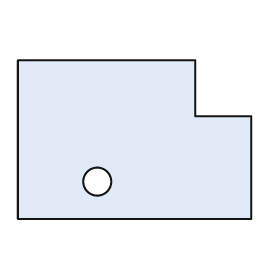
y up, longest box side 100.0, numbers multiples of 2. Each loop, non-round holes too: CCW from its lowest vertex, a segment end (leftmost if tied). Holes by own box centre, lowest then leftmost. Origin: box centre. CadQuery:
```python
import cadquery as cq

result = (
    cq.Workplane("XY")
    .moveTo(-50.0, -34.0)
    .lineTo(50.0, -34.0)
    .lineTo(50.0, 10.0)
    .lineTo(26.0, 10.0)
    .lineTo(26.0, 34.0)
    .lineTo(-50.0, 34.0)
    .close()
    .moveTo(-16.0, -18.0)
    .circle(6.0)
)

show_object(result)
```